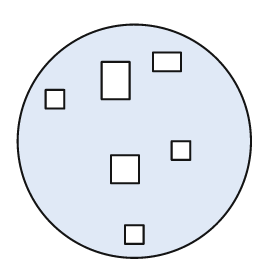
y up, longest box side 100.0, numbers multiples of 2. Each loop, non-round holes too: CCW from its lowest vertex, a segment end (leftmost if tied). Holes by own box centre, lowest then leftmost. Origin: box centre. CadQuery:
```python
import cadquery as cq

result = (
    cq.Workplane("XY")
    .moveTo(0.0, 0.0)
    .circle(50.0)
    .moveTo(-4.0, -44.0)
    .lineTo(4.0, -44.0)
    .lineTo(4.0, -36.0)
    .lineTo(-4.0, -36.0)
    .close()
    .moveTo(-10.0, -18.0)
    .lineTo(2.0, -18.0)
    .lineTo(2.0, -6.0)
    .lineTo(-10.0, -6.0)
    .close()
    .moveTo(16.0, -8.0)
    .lineTo(24.0, -8.0)
    .lineTo(24.0, 0.0)
    .lineTo(16.0, 0.0)
    .close()
    .moveTo(-38.0, 14.0)
    .lineTo(-30.0, 14.0)
    .lineTo(-30.0, 22.0)
    .lineTo(-38.0, 22.0)
    .close()
    .moveTo(-14.0, 18.0)
    .lineTo(-2.0, 18.0)
    .lineTo(-2.0, 34.0)
    .lineTo(-14.0, 34.0)
    .close()
    .moveTo(8.0, 30.0)
    .lineTo(20.0, 30.0)
    .lineTo(20.0, 38.0)
    .lineTo(8.0, 38.0)
    .close()
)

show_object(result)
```